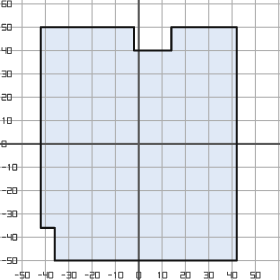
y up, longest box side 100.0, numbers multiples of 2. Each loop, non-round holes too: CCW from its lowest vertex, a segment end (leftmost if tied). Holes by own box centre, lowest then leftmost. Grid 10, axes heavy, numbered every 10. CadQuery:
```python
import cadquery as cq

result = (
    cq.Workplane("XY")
    .moveTo(-36.0, -50.0)
    .lineTo(42.0, -50.0)
    .lineTo(42.0, 50.0)
    .lineTo(14.0, 50.0)
    .lineTo(14.0, 40.0)
    .lineTo(-2.0, 40.0)
    .lineTo(-2.0, 50.0)
    .lineTo(-42.0, 50.0)
    .lineTo(-42.0, -36.0)
    .lineTo(-36.0, -36.0)
    .close()
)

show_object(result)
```